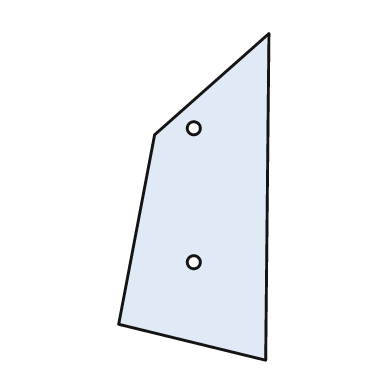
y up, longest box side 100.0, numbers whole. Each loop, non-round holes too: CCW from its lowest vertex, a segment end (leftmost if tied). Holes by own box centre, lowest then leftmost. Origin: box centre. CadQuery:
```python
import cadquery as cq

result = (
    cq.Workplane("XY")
    .moveTo(22.0, -50.0)
    .lineTo(23.0, 50.0)
    .lineTo(-12.0, 19.0)
    .lineTo(-23.0, -39.0)
    .close()
    .moveTo(0.0, -20.0)
    .circle(2.0)
    .moveTo(0.0, 21.0)
    .circle(2.0)
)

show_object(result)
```